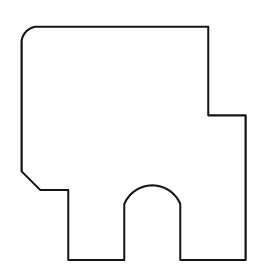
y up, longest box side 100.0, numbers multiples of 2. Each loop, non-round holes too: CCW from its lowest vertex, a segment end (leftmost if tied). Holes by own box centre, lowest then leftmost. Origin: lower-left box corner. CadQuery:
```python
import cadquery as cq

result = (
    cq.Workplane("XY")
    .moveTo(20.0, 0.0)
    .lineTo(44.0, 0.0)
    .lineTo(44.0, 24.0)
    .threePointArc((56.0, 32.0), (68.0, 24.0))
    .lineTo(68.0, 0.0)
    .lineTo(96.0, 0.0)
    .lineTo(96.0, 62.0)
    .lineTo(80.0, 62.0)
    .lineTo(80.0, 100.0)
    .lineTo(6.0, 100.0)
    .threePointArc((2.0, 98.0), (0.0, 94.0))
    .lineTo(0.0, 38.0)
    .lineTo(8.0, 30.0)
    .lineTo(20.0, 30.0)
    .close()
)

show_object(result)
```